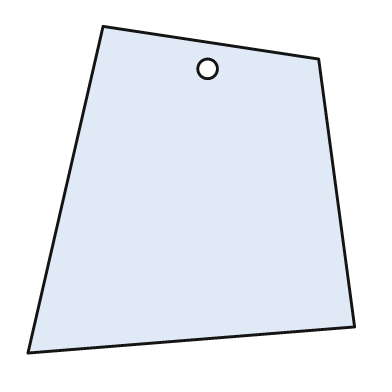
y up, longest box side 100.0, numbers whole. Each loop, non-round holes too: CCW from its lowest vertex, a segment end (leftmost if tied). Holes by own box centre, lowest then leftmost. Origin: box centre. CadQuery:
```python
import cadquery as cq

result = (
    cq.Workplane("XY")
    .moveTo(-50.0, -50.0)
    .lineTo(50.0, -42.0)
    .lineTo(39.0, 40.0)
    .lineTo(-27.0, 50.0)
    .close()
    .moveTo(5.0, 37.0)
    .circle(3.0)
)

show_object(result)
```